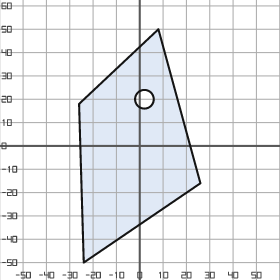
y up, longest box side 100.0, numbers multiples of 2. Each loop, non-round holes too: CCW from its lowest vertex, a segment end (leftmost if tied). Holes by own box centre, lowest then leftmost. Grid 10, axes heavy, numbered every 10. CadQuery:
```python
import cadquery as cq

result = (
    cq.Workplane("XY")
    .moveTo(-24.0, -50.0)
    .lineTo(26.0, -16.0)
    .lineTo(8.0, 50.0)
    .lineTo(-26.0, 18.0)
    .close()
    .moveTo(2.0, 20.0)
    .circle(4.0)
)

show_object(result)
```